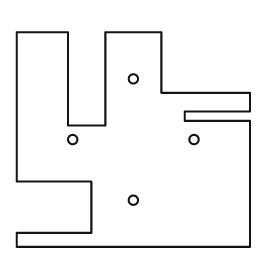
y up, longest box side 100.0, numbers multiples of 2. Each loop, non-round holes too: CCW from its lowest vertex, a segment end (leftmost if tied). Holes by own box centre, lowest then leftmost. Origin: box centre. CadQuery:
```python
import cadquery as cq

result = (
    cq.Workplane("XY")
    .moveTo(-50.0, -46.0)
    .lineTo(50.0, -46.0)
    .lineTo(50.0, 8.0)
    .lineTo(22.0, 8.0)
    .lineTo(22.0, 12.0)
    .lineTo(50.0, 12.0)
    .lineTo(50.0, 20.0)
    .lineTo(12.0, 20.0)
    .lineTo(12.0, 46.0)
    .lineTo(-12.0, 46.0)
    .lineTo(-12.0, 6.0)
    .lineTo(-28.0, 6.0)
    .lineTo(-28.0, 46.0)
    .lineTo(-50.0, 46.0)
    .lineTo(-50.0, -18.0)
    .lineTo(-18.0, -18.0)
    .lineTo(-18.0, -40.0)
    .lineTo(-50.0, -40.0)
    .close()
    .moveTo(0.0, -26.0)
    .circle(2.0)
    .moveTo(-26.0, 0.0)
    .circle(2.0)
    .moveTo(26.0, 0.0)
    .circle(2.0)
    .moveTo(0.0, 26.0)
    .circle(2.0)
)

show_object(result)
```